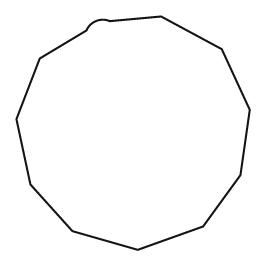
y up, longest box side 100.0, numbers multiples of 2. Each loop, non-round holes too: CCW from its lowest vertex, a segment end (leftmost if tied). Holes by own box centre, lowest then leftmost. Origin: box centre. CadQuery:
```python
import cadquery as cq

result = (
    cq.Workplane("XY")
    .moveTo(2.0, -50.0)
    .lineTo(30.0, -40.0)
    .lineTo(46.0, -18.0)
    .lineTo(50.0, 10.0)
    .lineTo(38.0, 36.0)
    .lineTo(12.0, 50.0)
    .lineTo(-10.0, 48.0)
    .threePointArc((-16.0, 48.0), (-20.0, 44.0))
    .lineTo(-40.0, 32.0)
    .lineTo(-50.0, 6.0)
    .lineTo(-44.0, -22.0)
    .lineTo(-26.0, -42.0)
    .close()
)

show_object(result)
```